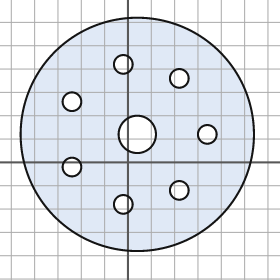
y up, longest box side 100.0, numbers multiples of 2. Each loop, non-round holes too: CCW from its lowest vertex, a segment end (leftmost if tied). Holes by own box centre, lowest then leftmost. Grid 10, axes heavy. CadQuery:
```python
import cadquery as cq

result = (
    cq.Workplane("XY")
    .moveTo(4.0, 12.0)
    .circle(50.0)
    .moveTo(-2.0, -18.0)
    .circle(4.0)
    .moveTo(22.0, -12.0)
    .circle(4.0)
    .moveTo(-24.0, -2.0)
    .circle(4.0)
    .moveTo(4.0, 12.0)
    .circle(8.0)
    .moveTo(34.0, 12.0)
    .circle(4.0)
    .moveTo(-24.0, 26.0)
    .circle(4.0)
    .moveTo(22.0, 36.0)
    .circle(4.0)
    .moveTo(-2.0, 42.0)
    .circle(4.0)
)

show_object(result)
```